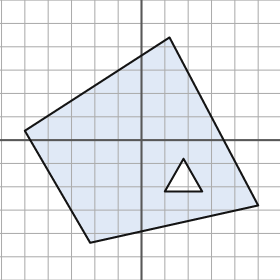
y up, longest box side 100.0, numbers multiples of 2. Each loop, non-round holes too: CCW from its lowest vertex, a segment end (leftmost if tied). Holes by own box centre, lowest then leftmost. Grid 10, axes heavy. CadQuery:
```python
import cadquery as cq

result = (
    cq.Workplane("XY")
    .moveTo(-22.0, -44.0)
    .lineTo(50.0, -28.0)
    .lineTo(12.0, 44.0)
    .lineTo(-50.0, 4.0)
    .close()
    .moveTo(10.0, -22.0)
    .lineTo(26.0, -22.0)
    .lineTo(18.0, -8.0)
    .close()
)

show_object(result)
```